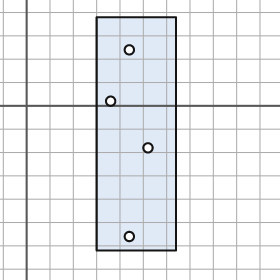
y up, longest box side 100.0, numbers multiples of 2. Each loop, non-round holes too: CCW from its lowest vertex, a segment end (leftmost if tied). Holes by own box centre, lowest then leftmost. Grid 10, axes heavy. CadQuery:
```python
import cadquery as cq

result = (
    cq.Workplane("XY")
    .moveTo(30.0, -62.0)
    .lineTo(64.0, -62.0)
    .lineTo(64.0, 38.0)
    .lineTo(30.0, 38.0)
    .close()
    .moveTo(44.0, -56.0)
    .circle(2.0)
    .moveTo(52.0, -18.0)
    .circle(2.0)
    .moveTo(36.0, 2.0)
    .circle(2.0)
    .moveTo(44.0, 24.0)
    .circle(2.0)
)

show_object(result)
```